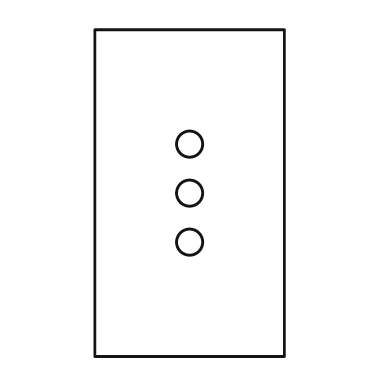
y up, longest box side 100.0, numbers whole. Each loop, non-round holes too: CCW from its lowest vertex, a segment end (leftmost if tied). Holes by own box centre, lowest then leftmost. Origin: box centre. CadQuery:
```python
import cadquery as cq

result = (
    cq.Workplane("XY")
    .moveTo(-29.0, -50.0)
    .lineTo(29.0, -50.0)
    .lineTo(29.0, 50.0)
    .lineTo(-29.0, 50.0)
    .close()
    .moveTo(0.0, -15.0)
    .circle(4.0)
    .moveTo(0.0, 0.0)
    .circle(4.0)
    .moveTo(0.0, 15.0)
    .circle(4.0)
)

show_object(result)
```